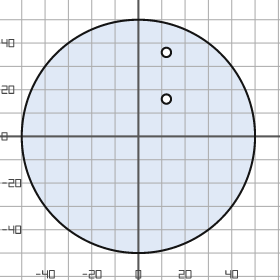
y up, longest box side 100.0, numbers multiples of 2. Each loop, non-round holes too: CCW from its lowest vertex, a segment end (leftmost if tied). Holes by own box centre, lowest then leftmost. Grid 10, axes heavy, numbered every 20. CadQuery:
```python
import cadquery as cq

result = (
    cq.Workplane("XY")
    .moveTo(0.0, 0.0)
    .circle(50.0)
    .moveTo(12.0, 16.0)
    .circle(2.0)
    .moveTo(12.0, 36.0)
    .circle(2.0)
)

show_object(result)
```